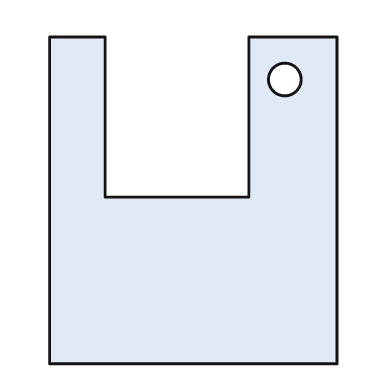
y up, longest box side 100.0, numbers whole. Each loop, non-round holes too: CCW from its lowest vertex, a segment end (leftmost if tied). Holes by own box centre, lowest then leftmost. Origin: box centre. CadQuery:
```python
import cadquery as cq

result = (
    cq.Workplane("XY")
    .moveTo(-44.0, -50.0)
    .lineTo(44.0, -50.0)
    .lineTo(44.0, 50.0)
    .lineTo(17.0, 50.0)
    .lineTo(17.0, 1.0)
    .lineTo(-27.0, 1.0)
    .lineTo(-27.0, 50.0)
    .lineTo(-44.0, 50.0)
    .close()
    .moveTo(28.0, 37.0)
    .circle(5.0)
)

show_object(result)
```